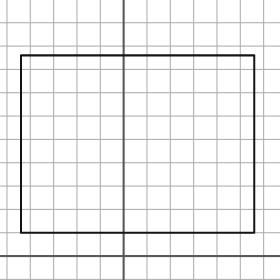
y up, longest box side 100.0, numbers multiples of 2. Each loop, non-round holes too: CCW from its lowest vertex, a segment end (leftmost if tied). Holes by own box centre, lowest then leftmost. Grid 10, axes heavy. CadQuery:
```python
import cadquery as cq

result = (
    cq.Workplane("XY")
    .moveTo(-44.0, 10.0)
    .lineTo(56.0, 10.0)
    .lineTo(56.0, 86.0)
    .lineTo(-44.0, 86.0)
    .close()
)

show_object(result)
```